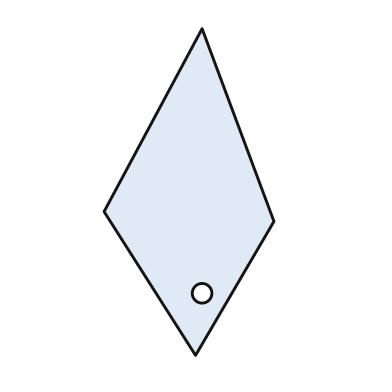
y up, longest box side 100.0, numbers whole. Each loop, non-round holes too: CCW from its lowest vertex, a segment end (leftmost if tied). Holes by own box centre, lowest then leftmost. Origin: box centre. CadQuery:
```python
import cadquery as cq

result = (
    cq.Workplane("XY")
    .moveTo(2.0, -50.0)
    .lineTo(26.0, -9.0)
    .lineTo(4.0, 50.0)
    .lineTo(-26.0, -6.0)
    .close()
    .moveTo(4.0, -31.0)
    .circle(3.0)
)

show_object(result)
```